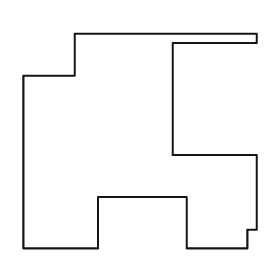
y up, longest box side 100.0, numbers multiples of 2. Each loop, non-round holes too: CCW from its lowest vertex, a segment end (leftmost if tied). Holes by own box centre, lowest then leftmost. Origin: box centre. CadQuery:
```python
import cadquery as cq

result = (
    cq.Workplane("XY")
    .moveTo(-50.0, -46.0)
    .lineTo(-18.0, -46.0)
    .lineTo(-18.0, -24.0)
    .lineTo(20.0, -24.0)
    .lineTo(20.0, -46.0)
    .lineTo(46.0, -46.0)
    .lineTo(46.0, -38.0)
    .lineTo(50.0, -38.0)
    .lineTo(50.0, -6.0)
    .lineTo(14.0, -6.0)
    .lineTo(14.0, 42.0)
    .lineTo(50.0, 42.0)
    .lineTo(50.0, 46.0)
    .lineTo(-28.0, 46.0)
    .lineTo(-28.0, 28.0)
    .lineTo(-50.0, 28.0)
    .close()
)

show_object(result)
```